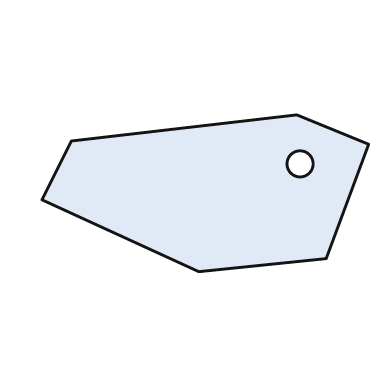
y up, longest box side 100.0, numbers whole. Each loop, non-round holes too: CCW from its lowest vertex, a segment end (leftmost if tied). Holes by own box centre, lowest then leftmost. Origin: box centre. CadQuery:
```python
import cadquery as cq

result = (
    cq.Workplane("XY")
    .moveTo(-2.0, -24.0)
    .lineTo(37.0, -20.0)
    .lineTo(50.0, 15.0)
    .lineTo(28.0, 24.0)
    .lineTo(-41.0, 16.0)
    .lineTo(-50.0, -2.0)
    .close()
    .moveTo(29.0, 9.0)
    .circle(4.0)
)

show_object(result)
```